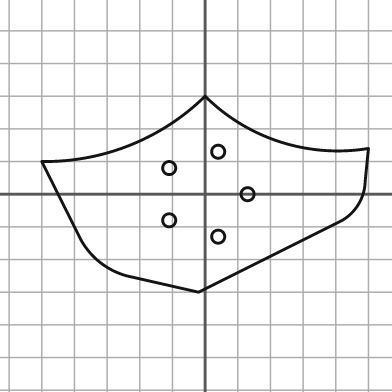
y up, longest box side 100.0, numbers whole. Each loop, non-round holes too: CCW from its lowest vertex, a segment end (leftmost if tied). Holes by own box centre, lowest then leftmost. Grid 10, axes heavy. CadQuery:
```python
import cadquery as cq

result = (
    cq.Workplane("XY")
    .moveTo(-2.0, -30.0)
    .lineTo(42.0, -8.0)
    .threePointArc((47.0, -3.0), (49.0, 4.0))
    .lineTo(50.0, 14.0)
    .threePointArc((23.0, 16.0), (0.0, 30.0))
    .threePointArc((-23.0, 15.0), (-50.0, 10.0))
    .lineTo(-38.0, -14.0)
    .threePointArc((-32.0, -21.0), (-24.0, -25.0))
    .close()
    .moveTo(4.0, -13.0)
    .circle(2.0)
    .moveTo(-11.0, -8.0)
    .circle(2.0)
    .moveTo(13.0, 0.0)
    .circle(2.0)
    .moveTo(-11.0, 8.0)
    .circle(2.0)
    .moveTo(4.0, 13.0)
    .circle(2.0)
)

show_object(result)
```